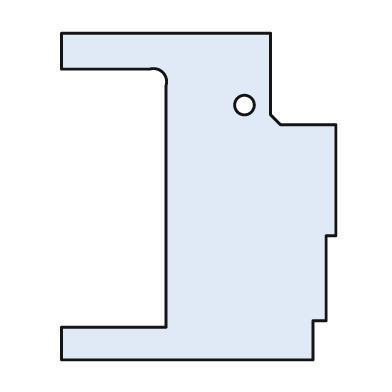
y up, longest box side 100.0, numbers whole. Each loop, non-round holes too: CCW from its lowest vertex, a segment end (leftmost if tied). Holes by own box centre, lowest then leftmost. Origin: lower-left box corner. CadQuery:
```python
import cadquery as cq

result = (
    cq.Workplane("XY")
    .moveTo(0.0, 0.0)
    .lineTo(77.0, 0.0)
    .lineTo(77.0, 12.0)
    .lineTo(81.0, 12.0)
    .lineTo(81.0, 38.0)
    .lineTo(84.0, 38.0)
    .lineTo(84.0, 72.0)
    .lineTo(67.0, 72.0)
    .lineTo(64.0, 75.0)
    .lineTo(64.0, 100.0)
    .lineTo(0.0, 100.0)
    .lineTo(0.0, 89.0)
    .lineTo(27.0, 89.0)
    .threePointArc((31.0, 88.0), (32.0, 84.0))
    .lineTo(32.0, 10.0)
    .lineTo(0.0, 10.0)
    .close()
    .moveTo(56.0, 78.0)
    .circle(3.0)
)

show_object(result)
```